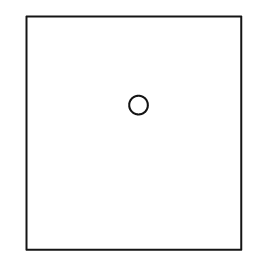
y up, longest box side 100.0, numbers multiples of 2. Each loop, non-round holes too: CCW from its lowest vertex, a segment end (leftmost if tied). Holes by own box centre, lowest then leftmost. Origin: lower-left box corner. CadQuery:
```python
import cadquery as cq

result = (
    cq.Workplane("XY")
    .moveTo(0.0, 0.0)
    .lineTo(92.0, 0.0)
    .lineTo(92.0, 100.0)
    .lineTo(0.0, 100.0)
    .close()
    .moveTo(48.0, 62.0)
    .circle(4.0)
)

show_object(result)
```